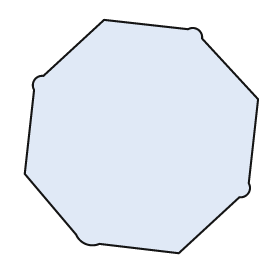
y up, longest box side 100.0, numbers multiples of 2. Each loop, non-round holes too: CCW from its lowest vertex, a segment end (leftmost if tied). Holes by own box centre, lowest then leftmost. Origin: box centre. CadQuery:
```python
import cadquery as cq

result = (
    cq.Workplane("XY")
    .moveTo(16.0, -50.0)
    .lineTo(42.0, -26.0)
    .threePointArc((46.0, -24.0), (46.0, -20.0))
    .lineTo(50.0, 16.0)
    .lineTo(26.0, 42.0)
    .threePointArc((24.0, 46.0), (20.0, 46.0))
    .lineTo(-16.0, 50.0)
    .lineTo(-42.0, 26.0)
    .threePointArc((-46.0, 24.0), (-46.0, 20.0))
    .lineTo(-50.0, -16.0)
    .lineTo(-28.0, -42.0)
    .threePointArc((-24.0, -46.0), (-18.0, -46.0))
    .close()
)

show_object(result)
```